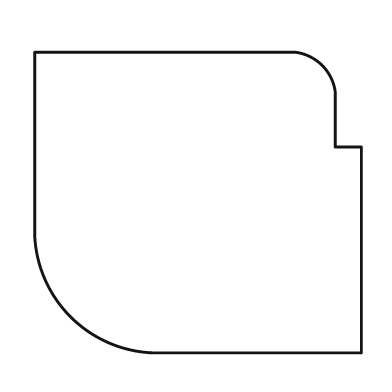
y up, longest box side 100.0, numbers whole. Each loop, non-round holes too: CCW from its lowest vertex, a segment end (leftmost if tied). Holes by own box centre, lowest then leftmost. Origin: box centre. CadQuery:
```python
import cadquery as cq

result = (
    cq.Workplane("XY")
    .moveTo(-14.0, -46.0)
    .lineTo(50.0, -46.0)
    .lineTo(50.0, 17.0)
    .lineTo(42.0, 17.0)
    .lineTo(42.0, 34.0)
    .threePointArc((38.0, 42.0), (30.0, 46.0))
    .lineTo(-50.0, 46.0)
    .lineTo(-50.0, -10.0)
    .threePointArc((-39.0, -35.0), (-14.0, -46.0))
    .close()
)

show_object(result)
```